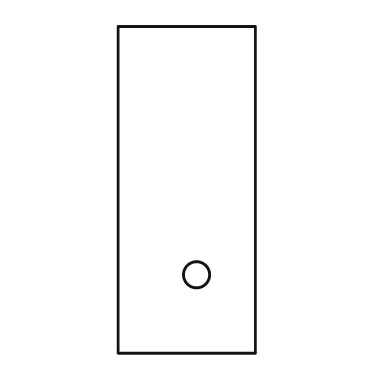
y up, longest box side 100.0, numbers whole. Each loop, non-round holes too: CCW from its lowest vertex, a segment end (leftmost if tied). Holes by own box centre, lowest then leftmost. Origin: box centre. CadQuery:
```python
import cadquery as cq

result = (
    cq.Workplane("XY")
    .moveTo(-21.0, -50.0)
    .lineTo(21.0, -50.0)
    .lineTo(21.0, 50.0)
    .lineTo(-21.0, 50.0)
    .close()
    .moveTo(3.0, -26.0)
    .circle(4.0)
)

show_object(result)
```